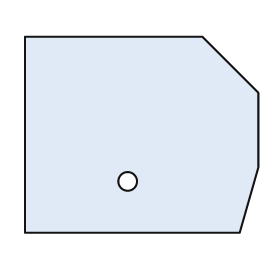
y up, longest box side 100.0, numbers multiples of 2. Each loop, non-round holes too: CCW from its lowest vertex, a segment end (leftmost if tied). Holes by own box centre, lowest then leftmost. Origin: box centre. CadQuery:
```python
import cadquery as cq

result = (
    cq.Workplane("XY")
    .moveTo(-50.0, -42.0)
    .lineTo(42.0, -42.0)
    .lineTo(50.0, -14.0)
    .lineTo(50.0, 18.0)
    .lineTo(26.0, 42.0)
    .lineTo(-50.0, 42.0)
    .close()
    .moveTo(-6.0, -20.0)
    .circle(4.0)
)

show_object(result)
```